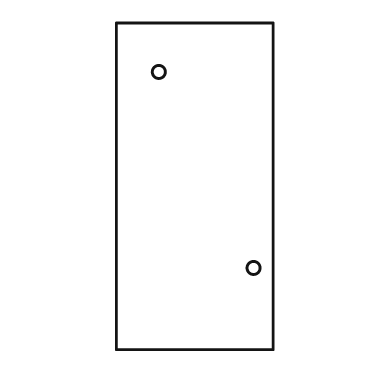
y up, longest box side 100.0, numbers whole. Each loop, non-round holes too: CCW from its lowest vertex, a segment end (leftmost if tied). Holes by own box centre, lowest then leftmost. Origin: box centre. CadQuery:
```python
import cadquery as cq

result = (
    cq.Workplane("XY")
    .moveTo(-24.0, -50.0)
    .lineTo(24.0, -50.0)
    .lineTo(24.0, 50.0)
    .lineTo(-24.0, 50.0)
    .close()
    .moveTo(18.0, -25.0)
    .circle(2.0)
    .moveTo(-11.0, 35.0)
    .circle(2.0)
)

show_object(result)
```